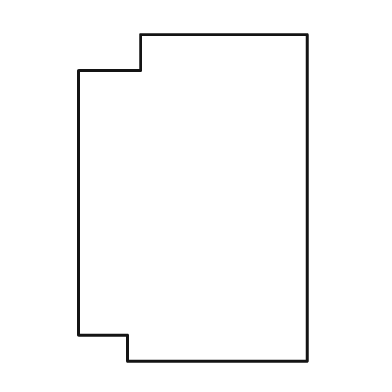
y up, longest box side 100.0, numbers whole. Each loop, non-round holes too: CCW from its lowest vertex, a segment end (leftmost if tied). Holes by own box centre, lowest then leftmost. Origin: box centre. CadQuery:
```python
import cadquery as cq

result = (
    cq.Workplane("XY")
    .moveTo(-20.0, -50.0)
    .lineTo(35.0, -50.0)
    .lineTo(35.0, 50.0)
    .lineTo(-16.0, 50.0)
    .lineTo(-16.0, 39.0)
    .lineTo(-35.0, 39.0)
    .lineTo(-35.0, -42.0)
    .lineTo(-20.0, -42.0)
    .close()
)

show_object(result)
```